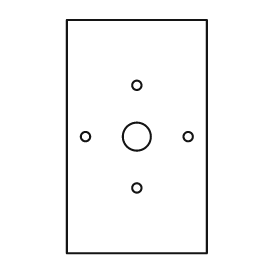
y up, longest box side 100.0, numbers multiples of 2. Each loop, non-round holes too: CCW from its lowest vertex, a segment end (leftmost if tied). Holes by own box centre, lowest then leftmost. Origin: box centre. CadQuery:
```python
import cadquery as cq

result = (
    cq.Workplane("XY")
    .moveTo(-30.0, -50.0)
    .lineTo(30.0, -50.0)
    .lineTo(30.0, 50.0)
    .lineTo(-30.0, 50.0)
    .close()
    .moveTo(0.0, -22.0)
    .circle(2.0)
    .moveTo(-22.0, 0.0)
    .circle(2.0)
    .moveTo(0.0, 0.0)
    .circle(6.0)
    .moveTo(22.0, 0.0)
    .circle(2.0)
    .moveTo(0.0, 22.0)
    .circle(2.0)
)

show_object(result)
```